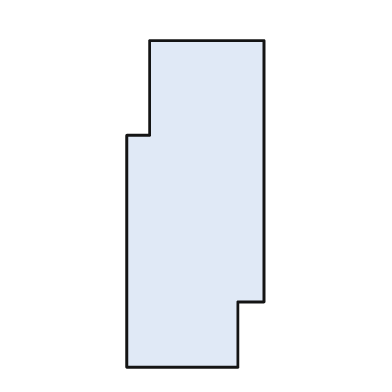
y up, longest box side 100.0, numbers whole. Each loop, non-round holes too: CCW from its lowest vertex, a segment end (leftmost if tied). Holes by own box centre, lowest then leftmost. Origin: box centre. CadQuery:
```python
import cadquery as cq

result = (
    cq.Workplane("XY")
    .moveTo(-21.0, -50.0)
    .lineTo(13.0, -50.0)
    .lineTo(13.0, -30.0)
    .lineTo(21.0, -30.0)
    .lineTo(21.0, 50.0)
    .lineTo(-14.0, 50.0)
    .lineTo(-14.0, 21.0)
    .lineTo(-21.0, 21.0)
    .close()
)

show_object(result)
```